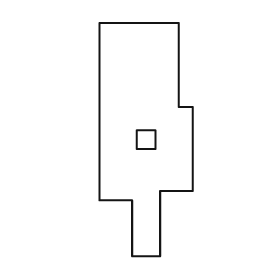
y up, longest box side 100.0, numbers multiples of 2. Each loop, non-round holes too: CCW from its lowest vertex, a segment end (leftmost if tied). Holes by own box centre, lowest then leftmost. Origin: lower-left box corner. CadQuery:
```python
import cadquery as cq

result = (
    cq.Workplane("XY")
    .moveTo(14.0, 0.0)
    .lineTo(26.0, 0.0)
    .lineTo(26.0, 28.0)
    .lineTo(40.0, 28.0)
    .lineTo(40.0, 64.0)
    .lineTo(34.0, 64.0)
    .lineTo(34.0, 100.0)
    .lineTo(0.0, 100.0)
    .lineTo(0.0, 24.0)
    .lineTo(14.0, 24.0)
    .close()
    .moveTo(16.0, 46.0)
    .lineTo(24.0, 46.0)
    .lineTo(24.0, 54.0)
    .lineTo(16.0, 54.0)
    .close()
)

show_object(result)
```